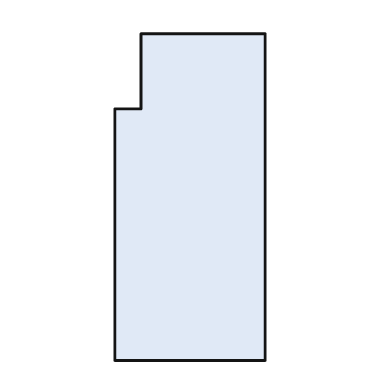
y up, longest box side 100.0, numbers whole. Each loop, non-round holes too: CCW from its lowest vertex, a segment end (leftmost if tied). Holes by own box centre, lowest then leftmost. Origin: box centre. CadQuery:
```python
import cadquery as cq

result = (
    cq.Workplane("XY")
    .moveTo(-23.0, -50.0)
    .lineTo(23.0, -50.0)
    .lineTo(23.0, 50.0)
    .lineTo(-15.0, 50.0)
    .lineTo(-15.0, 27.0)
    .lineTo(-23.0, 27.0)
    .close()
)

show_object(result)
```